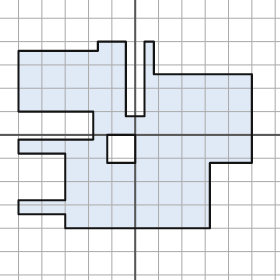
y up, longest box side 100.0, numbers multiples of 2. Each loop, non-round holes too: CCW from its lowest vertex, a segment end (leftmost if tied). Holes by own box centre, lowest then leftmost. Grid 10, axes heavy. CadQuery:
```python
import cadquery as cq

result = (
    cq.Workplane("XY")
    .moveTo(-30.0, -40.0)
    .lineTo(32.0, -40.0)
    .lineTo(32.0, -12.0)
    .lineTo(50.0, -12.0)
    .lineTo(50.0, 26.0)
    .lineTo(8.0, 26.0)
    .lineTo(8.0, 40.0)
    .lineTo(4.0, 40.0)
    .lineTo(4.0, 8.0)
    .lineTo(-4.0, 8.0)
    .lineTo(-4.0, 40.0)
    .lineTo(-16.0, 40.0)
    .lineTo(-16.0, 36.0)
    .lineTo(-50.0, 36.0)
    .lineTo(-50.0, 10.0)
    .lineTo(-18.0, 10.0)
    .lineTo(-18.0, -2.0)
    .lineTo(-50.0, -2.0)
    .lineTo(-50.0, -8.0)
    .lineTo(-30.0, -8.0)
    .lineTo(-30.0, -28.0)
    .lineTo(-50.0, -28.0)
    .lineTo(-50.0, -34.0)
    .lineTo(-30.0, -34.0)
    .close()
    .moveTo(-12.0, -12.0)
    .lineTo(0.0, -12.0)
    .lineTo(0.0, 0.0)
    .lineTo(-12.0, 0.0)
    .close()
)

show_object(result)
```